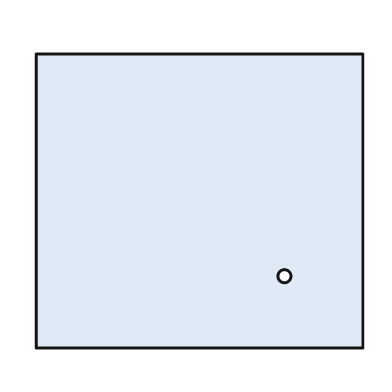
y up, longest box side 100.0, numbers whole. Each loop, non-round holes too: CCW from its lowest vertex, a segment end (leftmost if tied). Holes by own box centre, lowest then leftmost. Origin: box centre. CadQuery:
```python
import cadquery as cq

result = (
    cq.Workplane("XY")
    .moveTo(-50.0, -45.0)
    .lineTo(50.0, -45.0)
    .lineTo(50.0, 45.0)
    .lineTo(-50.0, 45.0)
    .close()
    .moveTo(26.0, -23.0)
    .circle(2.0)
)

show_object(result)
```